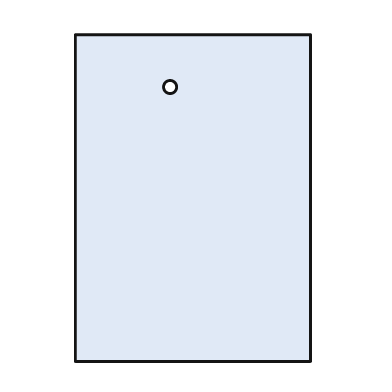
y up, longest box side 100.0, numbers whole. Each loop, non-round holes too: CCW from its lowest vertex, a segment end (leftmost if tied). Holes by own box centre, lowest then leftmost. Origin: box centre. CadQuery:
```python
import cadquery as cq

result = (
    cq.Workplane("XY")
    .moveTo(-36.0, -50.0)
    .lineTo(36.0, -50.0)
    .lineTo(36.0, 50.0)
    .lineTo(-36.0, 50.0)
    .close()
    .moveTo(-7.0, 34.0)
    .circle(2.0)
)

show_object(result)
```